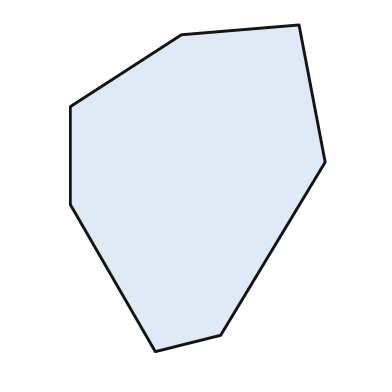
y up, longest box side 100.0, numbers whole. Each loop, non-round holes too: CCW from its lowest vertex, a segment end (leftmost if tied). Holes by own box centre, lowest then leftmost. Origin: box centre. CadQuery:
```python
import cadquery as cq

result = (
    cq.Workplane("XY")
    .moveTo(-13.0, -50.0)
    .lineTo(7.0, -45.0)
    .lineTo(39.0, 8.0)
    .lineTo(31.0, 50.0)
    .lineTo(-5.0, 47.0)
    .lineTo(-39.0, 25.0)
    .lineTo(-39.0, -5.0)
    .close()
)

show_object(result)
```